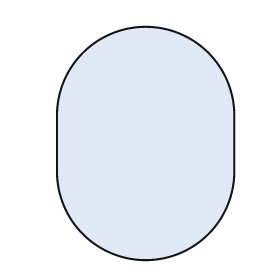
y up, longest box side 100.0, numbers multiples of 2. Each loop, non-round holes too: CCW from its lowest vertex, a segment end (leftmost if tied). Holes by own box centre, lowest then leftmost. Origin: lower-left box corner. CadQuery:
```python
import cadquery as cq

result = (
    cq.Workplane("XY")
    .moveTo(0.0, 38.0)
    .threePointArc((38.0, 0.0), (76.0, 38.0))
    .lineTo(76.0, 62.0)
    .threePointArc((38.0, 100.0), (0.0, 62.0))
    .close()
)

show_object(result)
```